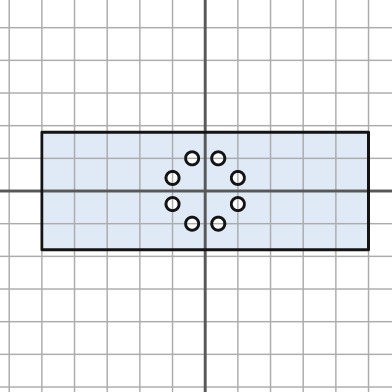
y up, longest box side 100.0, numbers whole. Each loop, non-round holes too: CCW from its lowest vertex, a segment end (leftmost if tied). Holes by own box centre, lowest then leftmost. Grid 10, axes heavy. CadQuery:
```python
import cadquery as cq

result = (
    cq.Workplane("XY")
    .moveTo(-50.0, -18.0)
    .lineTo(50.0, -18.0)
    .lineTo(50.0, 18.0)
    .lineTo(-50.0, 18.0)
    .close()
    .moveTo(-4.0, -10.0)
    .circle(2.0)
    .moveTo(4.0, -10.0)
    .circle(2.0)
    .moveTo(-10.0, -4.0)
    .circle(2.0)
    .moveTo(10.0, -4.0)
    .circle(2.0)
    .moveTo(-10.0, 4.0)
    .circle(2.0)
    .moveTo(10.0, 4.0)
    .circle(2.0)
    .moveTo(-4.0, 10.0)
    .circle(2.0)
    .moveTo(4.0, 10.0)
    .circle(2.0)
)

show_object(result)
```